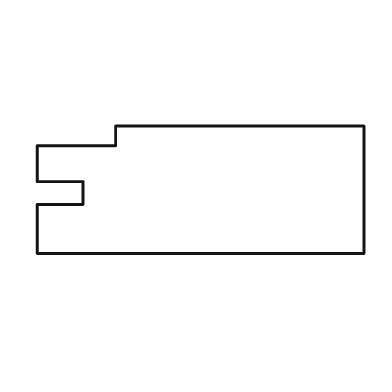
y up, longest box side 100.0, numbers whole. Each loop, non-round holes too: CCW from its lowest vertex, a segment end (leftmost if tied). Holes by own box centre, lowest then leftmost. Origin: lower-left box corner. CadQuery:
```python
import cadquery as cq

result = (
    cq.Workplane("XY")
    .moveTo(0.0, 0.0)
    .lineTo(100.0, 0.0)
    .lineTo(100.0, 39.0)
    .lineTo(24.0, 39.0)
    .lineTo(24.0, 33.0)
    .lineTo(0.0, 33.0)
    .lineTo(0.0, 22.0)
    .lineTo(14.0, 22.0)
    .lineTo(14.0, 15.0)
    .lineTo(0.0, 15.0)
    .close()
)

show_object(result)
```